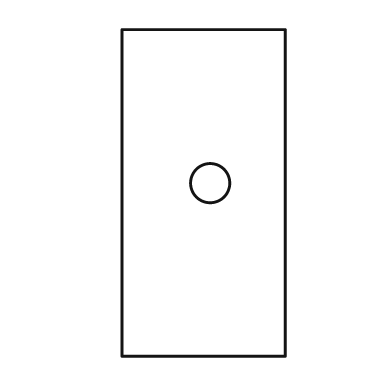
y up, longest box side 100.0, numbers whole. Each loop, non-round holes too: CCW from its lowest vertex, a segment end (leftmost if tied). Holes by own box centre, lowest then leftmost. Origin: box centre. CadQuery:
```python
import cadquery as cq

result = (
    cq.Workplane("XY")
    .moveTo(-25.0, -50.0)
    .lineTo(25.0, -50.0)
    .lineTo(25.0, 50.0)
    .lineTo(-25.0, 50.0)
    .close()
    .moveTo(2.0, 3.0)
    .circle(6.0)
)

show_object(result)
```